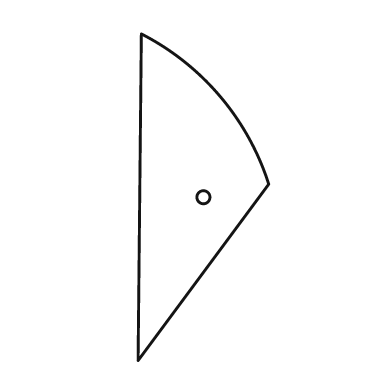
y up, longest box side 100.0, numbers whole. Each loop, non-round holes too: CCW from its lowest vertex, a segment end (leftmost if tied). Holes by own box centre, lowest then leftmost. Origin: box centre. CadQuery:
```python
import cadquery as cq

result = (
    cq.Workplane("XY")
    .moveTo(-20.0, -50.0)
    .lineTo(20.0, 4.0)
    .threePointArc((5.0, 31.0), (-19.0, 50.0))
    .close()
    .moveTo(0.0, 0.0)
    .circle(2.0)
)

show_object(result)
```